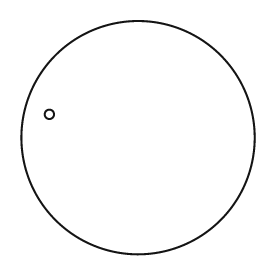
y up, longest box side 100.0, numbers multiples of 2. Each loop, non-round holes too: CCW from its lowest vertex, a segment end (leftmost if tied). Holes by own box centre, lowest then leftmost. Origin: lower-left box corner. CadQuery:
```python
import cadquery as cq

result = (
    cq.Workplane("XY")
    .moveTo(50.0, 50.0)
    .circle(50.0)
    .moveTo(12.0, 60.0)
    .circle(2.0)
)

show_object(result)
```